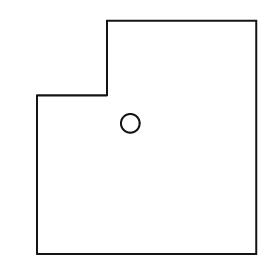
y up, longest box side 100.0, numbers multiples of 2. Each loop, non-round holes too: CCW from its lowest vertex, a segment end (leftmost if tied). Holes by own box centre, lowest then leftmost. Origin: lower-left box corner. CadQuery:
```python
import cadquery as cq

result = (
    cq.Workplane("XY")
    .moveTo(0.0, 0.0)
    .lineTo(94.0, 0.0)
    .lineTo(94.0, 100.0)
    .lineTo(30.0, 100.0)
    .lineTo(30.0, 68.0)
    .lineTo(0.0, 68.0)
    .close()
    .moveTo(40.0, 56.0)
    .circle(4.0)
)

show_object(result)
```